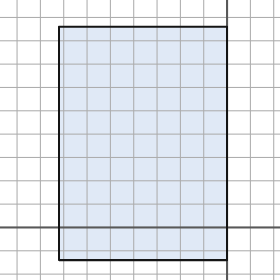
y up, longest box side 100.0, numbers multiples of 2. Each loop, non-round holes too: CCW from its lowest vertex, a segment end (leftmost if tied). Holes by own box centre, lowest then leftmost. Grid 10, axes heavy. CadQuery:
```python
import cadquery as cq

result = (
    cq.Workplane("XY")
    .moveTo(-72.0, -14.0)
    .lineTo(0.0, -14.0)
    .lineTo(0.0, 86.0)
    .lineTo(-72.0, 86.0)
    .close()
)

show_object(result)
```